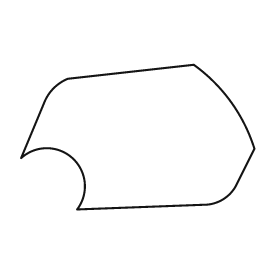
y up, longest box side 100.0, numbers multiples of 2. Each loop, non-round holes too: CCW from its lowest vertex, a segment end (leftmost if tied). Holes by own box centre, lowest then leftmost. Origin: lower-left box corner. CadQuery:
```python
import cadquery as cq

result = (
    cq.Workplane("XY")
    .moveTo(24.0, 0.0)
    .lineTo(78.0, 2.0)
    .threePointArc((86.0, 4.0), (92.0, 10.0))
    .lineTo(100.0, 26.0)
    .threePointArc((90.0, 46.0), (74.0, 62.0))
    .lineTo(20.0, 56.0)
    .threePointArc((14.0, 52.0), (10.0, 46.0))
    .lineTo(0.0, 22.0)
    .threePointArc((22.0, 22.0), (24.0, 0.0))
    .close()
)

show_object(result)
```